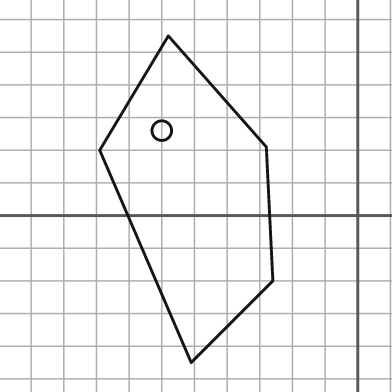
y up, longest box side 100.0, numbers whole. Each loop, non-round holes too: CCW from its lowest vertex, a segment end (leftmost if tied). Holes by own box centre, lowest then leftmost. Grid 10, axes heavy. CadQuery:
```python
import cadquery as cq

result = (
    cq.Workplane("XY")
    .moveTo(-51.0, -45.0)
    .lineTo(-26.0, -20.0)
    .lineTo(-28.0, 21.0)
    .lineTo(-58.0, 55.0)
    .lineTo(-79.0, 20.0)
    .close()
    .moveTo(-60.0, 26.0)
    .circle(3.0)
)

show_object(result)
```